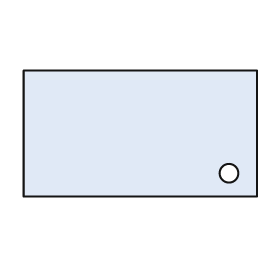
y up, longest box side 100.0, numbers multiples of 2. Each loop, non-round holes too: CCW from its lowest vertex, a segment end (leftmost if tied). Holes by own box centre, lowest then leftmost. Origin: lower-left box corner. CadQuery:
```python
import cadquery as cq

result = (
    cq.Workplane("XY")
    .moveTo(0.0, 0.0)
    .lineTo(100.0, 0.0)
    .lineTo(100.0, 54.0)
    .lineTo(0.0, 54.0)
    .close()
    .moveTo(88.0, 10.0)
    .circle(4.0)
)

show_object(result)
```